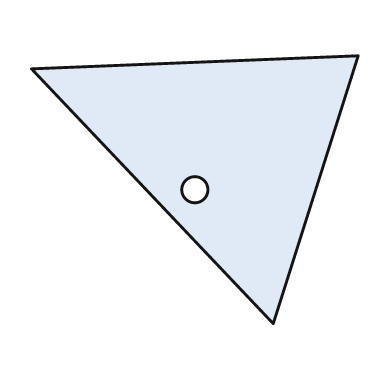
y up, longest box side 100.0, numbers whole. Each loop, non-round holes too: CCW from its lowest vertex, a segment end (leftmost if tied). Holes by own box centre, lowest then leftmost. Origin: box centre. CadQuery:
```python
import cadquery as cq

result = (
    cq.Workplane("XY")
    .moveTo(24.0, -41.0)
    .lineTo(50.0, 41.0)
    .lineTo(-50.0, 37.0)
    .close()
    .moveTo(0.0, 0.0)
    .circle(4.0)
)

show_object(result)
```